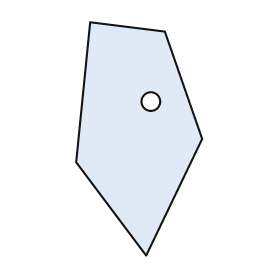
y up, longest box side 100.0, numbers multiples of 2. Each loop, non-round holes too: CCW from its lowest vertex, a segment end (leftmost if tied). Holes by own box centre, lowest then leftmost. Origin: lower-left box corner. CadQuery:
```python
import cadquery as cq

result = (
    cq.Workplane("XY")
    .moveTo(30.0, 0.0)
    .lineTo(54.0, 50.0)
    .lineTo(38.0, 96.0)
    .lineTo(6.0, 100.0)
    .lineTo(0.0, 40.0)
    .close()
    .moveTo(32.0, 66.0)
    .circle(4.0)
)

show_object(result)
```